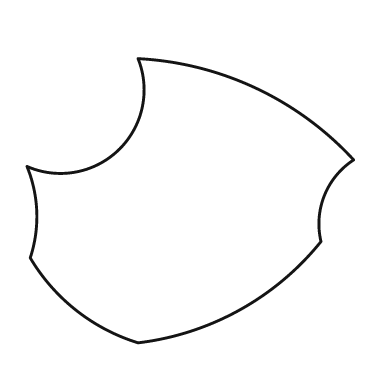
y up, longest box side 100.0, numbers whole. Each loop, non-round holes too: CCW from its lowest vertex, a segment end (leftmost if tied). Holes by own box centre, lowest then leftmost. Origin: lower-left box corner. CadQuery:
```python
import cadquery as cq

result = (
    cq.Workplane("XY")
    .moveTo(34.0, 0.0)
    .threePointArc((65.0, 10.0), (90.0, 31.0))
    .threePointArc((91.0, 45.0), (100.0, 56.0))
    .threePointArc((70.0, 78.0), (34.0, 87.0))
    .threePointArc((28.0, 59.0), (0.0, 54.0))
    .threePointArc((3.0, 40.0), (1.0, 26.0))
    .threePointArc((15.0, 10.0), (34.0, 0.0))
    .close()
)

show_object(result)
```